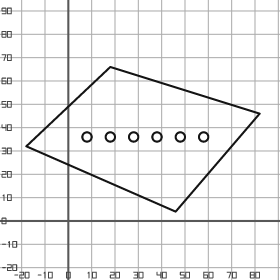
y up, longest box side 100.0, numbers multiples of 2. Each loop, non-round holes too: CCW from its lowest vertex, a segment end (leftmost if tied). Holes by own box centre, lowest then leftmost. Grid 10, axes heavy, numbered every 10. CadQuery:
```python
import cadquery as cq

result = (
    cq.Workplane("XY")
    .moveTo(46.0, 4.0)
    .lineTo(82.0, 46.0)
    .lineTo(18.0, 66.0)
    .lineTo(-18.0, 32.0)
    .close()
    .moveTo(8.0, 36.0)
    .circle(2.0)
    .moveTo(18.0, 36.0)
    .circle(2.0)
    .moveTo(28.0, 36.0)
    .circle(2.0)
    .moveTo(38.0, 36.0)
    .circle(2.0)
    .moveTo(48.0, 36.0)
    .circle(2.0)
    .moveTo(58.0, 36.0)
    .circle(2.0)
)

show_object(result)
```